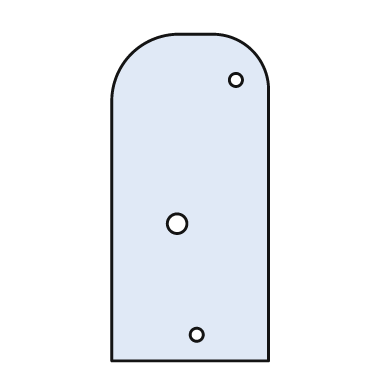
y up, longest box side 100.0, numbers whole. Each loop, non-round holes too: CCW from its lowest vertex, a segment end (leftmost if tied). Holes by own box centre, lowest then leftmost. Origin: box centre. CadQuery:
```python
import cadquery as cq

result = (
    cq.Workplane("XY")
    .moveTo(-24.0, -50.0)
    .lineTo(24.0, -50.0)
    .lineTo(24.0, 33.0)
    .threePointArc((19.0, 45.0), (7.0, 50.0))
    .lineTo(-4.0, 50.0)
    .threePointArc((-18.0, 44.0), (-24.0, 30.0))
    .close()
    .moveTo(2.0, -42.0)
    .circle(2.0)
    .moveTo(-4.0, -8.0)
    .circle(3.0)
    .moveTo(14.0, 36.0)
    .circle(2.0)
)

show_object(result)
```